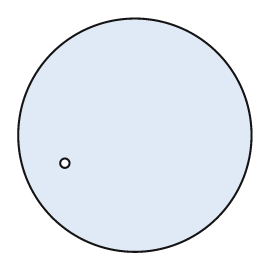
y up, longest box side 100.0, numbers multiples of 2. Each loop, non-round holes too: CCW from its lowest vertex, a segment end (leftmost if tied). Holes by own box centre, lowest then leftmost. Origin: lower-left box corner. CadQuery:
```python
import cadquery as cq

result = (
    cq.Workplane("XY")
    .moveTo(50.0, 50.0)
    .circle(50.0)
    .moveTo(20.0, 38.0)
    .circle(2.0)
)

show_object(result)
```